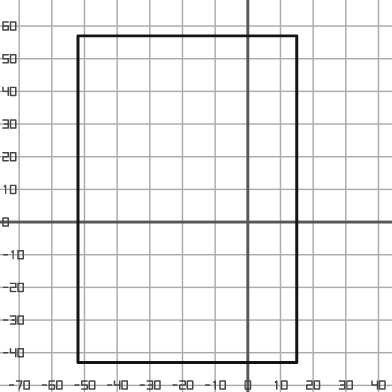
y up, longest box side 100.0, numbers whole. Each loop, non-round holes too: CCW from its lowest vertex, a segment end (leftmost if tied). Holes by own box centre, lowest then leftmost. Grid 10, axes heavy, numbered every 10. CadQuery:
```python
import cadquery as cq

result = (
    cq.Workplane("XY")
    .moveTo(-52.0, -43.0)
    .lineTo(15.0, -43.0)
    .lineTo(15.0, 57.0)
    .lineTo(-52.0, 57.0)
    .close()
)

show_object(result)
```